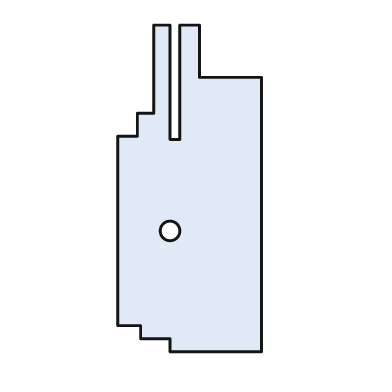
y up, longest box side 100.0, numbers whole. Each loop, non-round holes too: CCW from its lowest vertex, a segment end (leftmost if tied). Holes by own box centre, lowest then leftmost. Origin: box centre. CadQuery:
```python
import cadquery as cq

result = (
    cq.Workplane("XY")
    .moveTo(-6.0, -50.0)
    .lineTo(22.0, -50.0)
    .lineTo(22.0, 34.0)
    .lineTo(3.0, 34.0)
    .lineTo(3.0, 50.0)
    .lineTo(-3.0, 50.0)
    .lineTo(-3.0, 15.0)
    .lineTo(-6.0, 15.0)
    .lineTo(-6.0, 50.0)
    .lineTo(-11.0, 50.0)
    .lineTo(-11.0, 23.0)
    .lineTo(-16.0, 23.0)
    .lineTo(-16.0, 16.0)
    .lineTo(-22.0, 16.0)
    .lineTo(-22.0, -42.0)
    .lineTo(-15.0, -42.0)
    .lineTo(-15.0, -46.0)
    .lineTo(-6.0, -46.0)
    .close()
    .moveTo(-6.0, -13.0)
    .circle(3.0)
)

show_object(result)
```